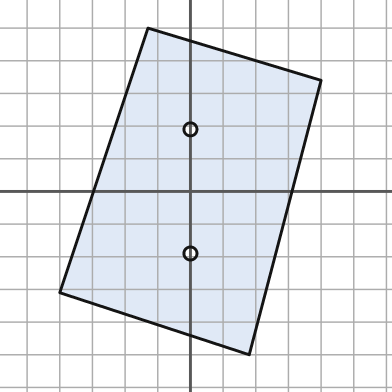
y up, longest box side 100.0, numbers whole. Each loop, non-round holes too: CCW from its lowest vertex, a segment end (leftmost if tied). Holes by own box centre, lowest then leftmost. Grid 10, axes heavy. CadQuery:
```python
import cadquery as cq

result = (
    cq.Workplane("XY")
    .moveTo(18.0, -50.0)
    .lineTo(40.0, 34.0)
    .lineTo(-13.0, 50.0)
    .lineTo(-40.0, -31.0)
    .close()
    .moveTo(0.0, -19.0)
    .circle(2.0)
    .moveTo(0.0, 19.0)
    .circle(2.0)
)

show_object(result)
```